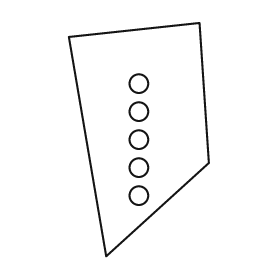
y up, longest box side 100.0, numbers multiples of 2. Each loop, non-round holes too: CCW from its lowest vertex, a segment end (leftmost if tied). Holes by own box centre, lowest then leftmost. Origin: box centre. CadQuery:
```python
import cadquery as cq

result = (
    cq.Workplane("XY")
    .moveTo(-14.0, -50.0)
    .lineTo(30.0, -10.0)
    .lineTo(26.0, 50.0)
    .lineTo(-30.0, 44.0)
    .close()
    .moveTo(0.0, -24.0)
    .circle(4.0)
    .moveTo(0.0, -12.0)
    .circle(4.0)
    .moveTo(0.0, 0.0)
    .circle(4.0)
    .moveTo(0.0, 12.0)
    .circle(4.0)
    .moveTo(0.0, 24.0)
    .circle(4.0)
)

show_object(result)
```